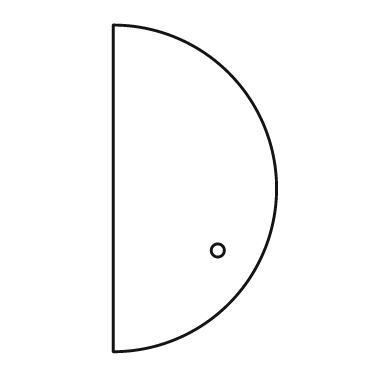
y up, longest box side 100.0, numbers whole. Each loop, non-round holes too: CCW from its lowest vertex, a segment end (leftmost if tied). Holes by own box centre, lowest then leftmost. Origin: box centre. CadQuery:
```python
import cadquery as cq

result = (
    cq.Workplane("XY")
    .moveTo(-25.0, -50.0)
    .threePointArc((25.0, 0.0), (-25.0, 50.0))
    .close()
    .moveTo(7.0, -19.0)
    .circle(2.0)
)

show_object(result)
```